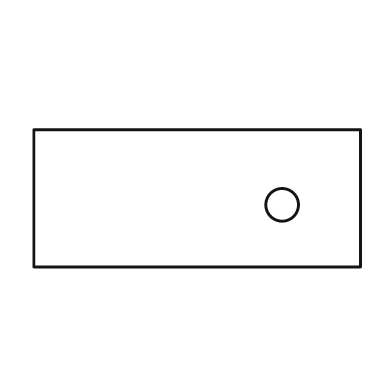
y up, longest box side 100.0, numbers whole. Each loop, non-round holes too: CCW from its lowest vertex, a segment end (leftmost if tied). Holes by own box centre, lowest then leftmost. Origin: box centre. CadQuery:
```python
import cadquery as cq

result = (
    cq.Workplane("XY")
    .moveTo(-50.0, -21.0)
    .lineTo(50.0, -21.0)
    .lineTo(50.0, 21.0)
    .lineTo(-50.0, 21.0)
    .close()
    .moveTo(26.0, -2.0)
    .circle(5.0)
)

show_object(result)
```